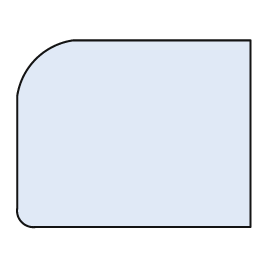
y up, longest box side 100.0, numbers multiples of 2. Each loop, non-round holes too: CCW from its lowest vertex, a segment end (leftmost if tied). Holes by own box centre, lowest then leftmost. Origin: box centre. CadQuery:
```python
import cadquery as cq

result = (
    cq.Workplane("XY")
    .moveTo(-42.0, -40.0)
    .lineTo(50.0, -40.0)
    .lineTo(50.0, 40.0)
    .lineTo(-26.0, 40.0)
    .threePointArc((-42.0, 32.0), (-50.0, 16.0))
    .lineTo(-50.0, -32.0)
    .threePointArc((-48.0, -38.0), (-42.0, -40.0))
    .close()
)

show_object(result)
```